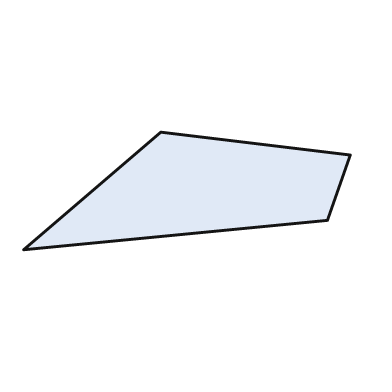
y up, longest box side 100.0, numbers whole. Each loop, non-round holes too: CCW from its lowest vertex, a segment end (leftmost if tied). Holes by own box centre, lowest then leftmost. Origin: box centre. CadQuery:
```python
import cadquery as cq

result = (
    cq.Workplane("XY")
    .moveTo(-50.0, -18.0)
    .lineTo(43.0, -9.0)
    .lineTo(50.0, 11.0)
    .lineTo(-8.0, 18.0)
    .close()
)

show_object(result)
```